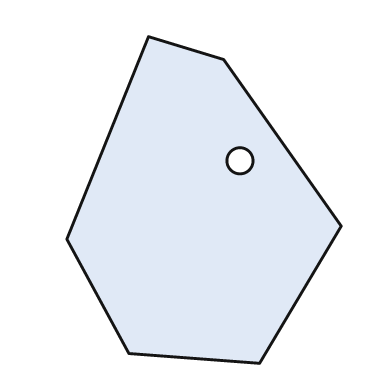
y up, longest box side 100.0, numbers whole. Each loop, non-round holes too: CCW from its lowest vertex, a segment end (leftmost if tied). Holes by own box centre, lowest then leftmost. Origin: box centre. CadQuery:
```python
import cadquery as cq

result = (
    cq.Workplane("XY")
    .moveTo(17.0, -50.0)
    .lineTo(42.0, -8.0)
    .lineTo(6.0, 43.0)
    .lineTo(-17.0, 50.0)
    .lineTo(-42.0, -12.0)
    .lineTo(-23.0, -47.0)
    .close()
    .moveTo(11.0, 12.0)
    .circle(4.0)
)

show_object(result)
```